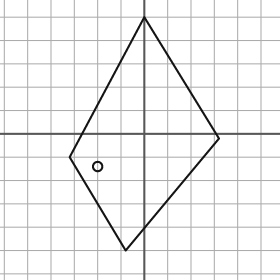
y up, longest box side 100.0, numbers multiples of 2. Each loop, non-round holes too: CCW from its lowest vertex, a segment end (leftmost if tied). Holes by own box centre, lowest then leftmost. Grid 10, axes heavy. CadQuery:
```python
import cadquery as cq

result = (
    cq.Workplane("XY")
    .moveTo(-8.0, -50.0)
    .lineTo(32.0, -2.0)
    .lineTo(0.0, 50.0)
    .lineTo(-32.0, -10.0)
    .close()
    .moveTo(-20.0, -14.0)
    .circle(2.0)
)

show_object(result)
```